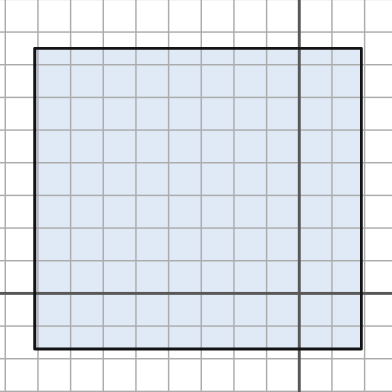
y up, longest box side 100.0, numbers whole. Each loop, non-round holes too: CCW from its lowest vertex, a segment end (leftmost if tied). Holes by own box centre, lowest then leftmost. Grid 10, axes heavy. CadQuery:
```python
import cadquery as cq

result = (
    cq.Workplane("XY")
    .moveTo(-81.0, -17.0)
    .lineTo(19.0, -17.0)
    .lineTo(19.0, 75.0)
    .lineTo(-81.0, 75.0)
    .close()
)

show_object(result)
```